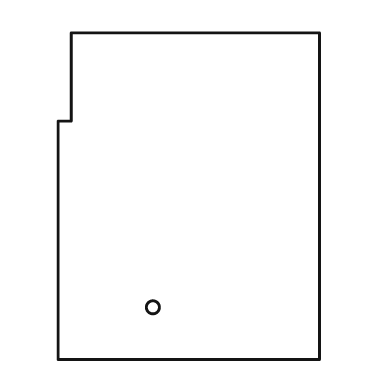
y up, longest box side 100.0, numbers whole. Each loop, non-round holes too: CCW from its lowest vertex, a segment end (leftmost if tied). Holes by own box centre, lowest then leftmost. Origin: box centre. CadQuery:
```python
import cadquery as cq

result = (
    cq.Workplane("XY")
    .moveTo(-40.0, -50.0)
    .lineTo(40.0, -50.0)
    .lineTo(40.0, 50.0)
    .lineTo(-36.0, 50.0)
    .lineTo(-36.0, 23.0)
    .lineTo(-40.0, 23.0)
    .close()
    .moveTo(-11.0, -34.0)
    .circle(2.0)
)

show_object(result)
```